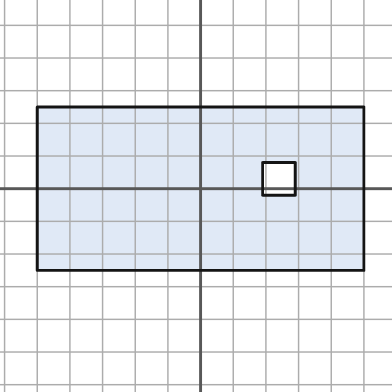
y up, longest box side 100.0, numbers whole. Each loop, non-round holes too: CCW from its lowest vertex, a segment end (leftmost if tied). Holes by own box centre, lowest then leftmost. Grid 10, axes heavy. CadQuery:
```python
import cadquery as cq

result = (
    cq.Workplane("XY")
    .moveTo(-50.0, -25.0)
    .lineTo(50.0, -25.0)
    .lineTo(50.0, 25.0)
    .lineTo(-50.0, 25.0)
    .close()
    .moveTo(19.0, -2.0)
    .lineTo(29.0, -2.0)
    .lineTo(29.0, 8.0)
    .lineTo(19.0, 8.0)
    .close()
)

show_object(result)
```